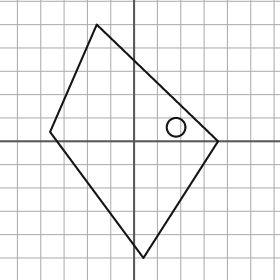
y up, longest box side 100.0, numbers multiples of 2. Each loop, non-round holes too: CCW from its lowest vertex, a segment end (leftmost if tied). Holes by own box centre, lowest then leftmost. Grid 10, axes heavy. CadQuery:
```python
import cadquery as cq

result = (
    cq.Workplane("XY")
    .moveTo(4.0, -50.0)
    .lineTo(36.0, 0.0)
    .lineTo(-16.0, 50.0)
    .lineTo(-36.0, 4.0)
    .close()
    .moveTo(18.0, 6.0)
    .circle(4.0)
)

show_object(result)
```